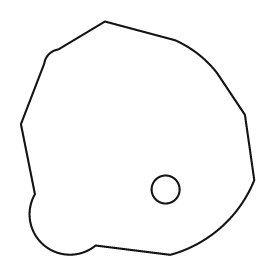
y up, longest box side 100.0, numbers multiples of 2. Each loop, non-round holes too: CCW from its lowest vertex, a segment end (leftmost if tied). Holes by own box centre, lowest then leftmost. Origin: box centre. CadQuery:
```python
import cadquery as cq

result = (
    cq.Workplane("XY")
    .moveTo(14.0, -50.0)
    .threePointArc((36.0, -38.0), (50.0, -18.0))
    .lineTo(46.0, 10.0)
    .lineTo(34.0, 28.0)
    .threePointArc((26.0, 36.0), (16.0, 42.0))
    .lineTo(-14.0, 50.0)
    .lineTo(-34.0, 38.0)
    .threePointArc((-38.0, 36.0), (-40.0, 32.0))
    .lineTo(-50.0, 6.0)
    .lineTo(-44.0, -24.0)
    .threePointArc((-40.0, -46.0), (-18.0, -46.0))
    .close()
    .moveTo(12.0, -22.0)
    .circle(6.0)
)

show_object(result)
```